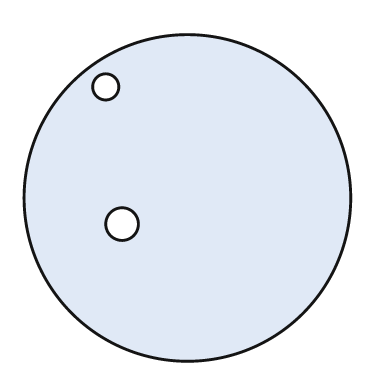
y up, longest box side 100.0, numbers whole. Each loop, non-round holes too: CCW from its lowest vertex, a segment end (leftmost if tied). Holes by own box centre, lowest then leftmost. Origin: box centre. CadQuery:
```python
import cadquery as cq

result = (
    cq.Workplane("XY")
    .moveTo(0.0, 0.0)
    .circle(50.0)
    .moveTo(-20.0, -8.0)
    .circle(5.0)
    .moveTo(-25.0, 34.0)
    .circle(4.0)
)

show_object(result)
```